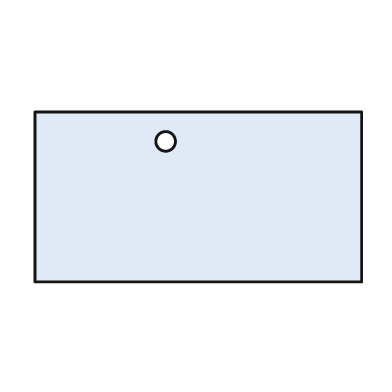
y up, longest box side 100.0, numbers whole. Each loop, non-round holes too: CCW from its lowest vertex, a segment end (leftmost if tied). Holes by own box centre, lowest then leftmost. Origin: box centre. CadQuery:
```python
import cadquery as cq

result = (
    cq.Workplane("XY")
    .moveTo(-50.0, -26.0)
    .lineTo(50.0, -26.0)
    .lineTo(50.0, 26.0)
    .lineTo(-50.0, 26.0)
    .close()
    .moveTo(-10.0, 17.0)
    .circle(3.0)
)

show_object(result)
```